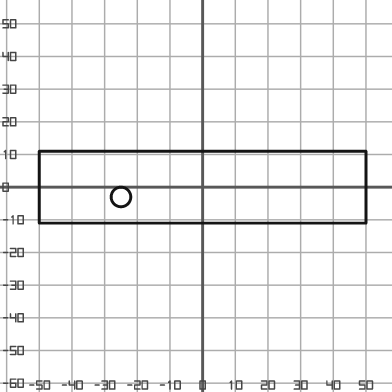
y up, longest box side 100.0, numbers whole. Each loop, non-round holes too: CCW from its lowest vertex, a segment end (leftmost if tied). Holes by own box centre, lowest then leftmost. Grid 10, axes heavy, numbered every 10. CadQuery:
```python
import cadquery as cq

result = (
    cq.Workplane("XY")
    .moveTo(-50.0, -11.0)
    .lineTo(50.0, -11.0)
    .lineTo(50.0, 11.0)
    .lineTo(-50.0, 11.0)
    .close()
    .moveTo(-25.0, -3.0)
    .circle(3.0)
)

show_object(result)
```